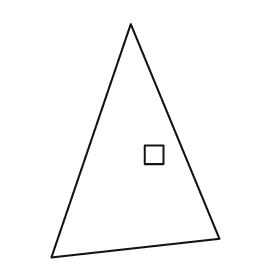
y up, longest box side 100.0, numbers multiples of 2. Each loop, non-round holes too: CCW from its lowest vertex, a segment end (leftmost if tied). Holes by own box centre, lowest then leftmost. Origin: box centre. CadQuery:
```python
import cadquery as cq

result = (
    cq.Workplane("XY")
    .moveTo(-36.0, -50.0)
    .lineTo(36.0, -42.0)
    .lineTo(-2.0, 50.0)
    .close()
    .moveTo(4.0, -10.0)
    .lineTo(12.0, -10.0)
    .lineTo(12.0, -2.0)
    .lineTo(4.0, -2.0)
    .close()
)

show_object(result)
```